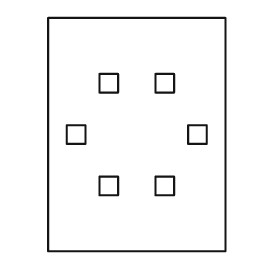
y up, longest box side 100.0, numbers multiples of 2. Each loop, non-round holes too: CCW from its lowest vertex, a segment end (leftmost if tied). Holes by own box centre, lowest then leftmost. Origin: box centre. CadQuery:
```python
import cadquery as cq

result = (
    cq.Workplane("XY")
    .moveTo(-38.0, -50.0)
    .lineTo(38.0, -50.0)
    .lineTo(38.0, 50.0)
    .lineTo(-38.0, 50.0)
    .close()
    .moveTo(-16.0, -26.0)
    .lineTo(-8.0, -26.0)
    .lineTo(-8.0, -18.0)
    .lineTo(-16.0, -18.0)
    .close()
    .moveTo(8.0, -26.0)
    .lineTo(16.0, -26.0)
    .lineTo(16.0, -18.0)
    .lineTo(8.0, -18.0)
    .close()
    .moveTo(-30.0, -4.0)
    .lineTo(-22.0, -4.0)
    .lineTo(-22.0, 4.0)
    .lineTo(-30.0, 4.0)
    .close()
    .moveTo(22.0, -4.0)
    .lineTo(30.0, -4.0)
    .lineTo(30.0, 4.0)
    .lineTo(22.0, 4.0)
    .close()
    .moveTo(-16.0, 18.0)
    .lineTo(-8.0, 18.0)
    .lineTo(-8.0, 26.0)
    .lineTo(-16.0, 26.0)
    .close()
    .moveTo(8.0, 18.0)
    .lineTo(16.0, 18.0)
    .lineTo(16.0, 26.0)
    .lineTo(8.0, 26.0)
    .close()
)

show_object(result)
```